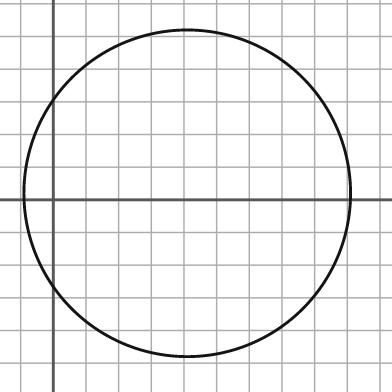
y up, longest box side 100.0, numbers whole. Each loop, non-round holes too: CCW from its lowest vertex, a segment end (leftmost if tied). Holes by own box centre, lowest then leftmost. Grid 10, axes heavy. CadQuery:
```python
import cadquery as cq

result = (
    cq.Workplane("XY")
    .moveTo(41.0, 2.0)
    .circle(50.0)
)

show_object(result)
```